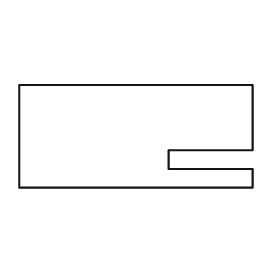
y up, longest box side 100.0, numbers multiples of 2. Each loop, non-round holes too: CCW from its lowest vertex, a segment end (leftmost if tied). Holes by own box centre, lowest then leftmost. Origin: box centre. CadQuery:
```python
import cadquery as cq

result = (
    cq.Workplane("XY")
    .moveTo(-50.0, -22.0)
    .lineTo(50.0, -22.0)
    .lineTo(50.0, -14.0)
    .lineTo(14.0, -14.0)
    .lineTo(14.0, -6.0)
    .lineTo(50.0, -6.0)
    .lineTo(50.0, 22.0)
    .lineTo(-50.0, 22.0)
    .close()
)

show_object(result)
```